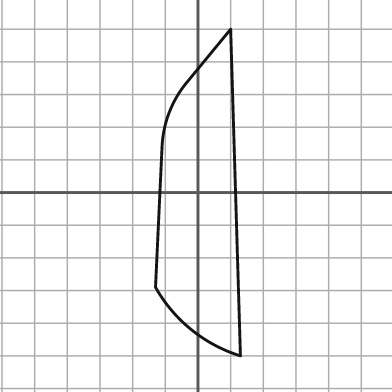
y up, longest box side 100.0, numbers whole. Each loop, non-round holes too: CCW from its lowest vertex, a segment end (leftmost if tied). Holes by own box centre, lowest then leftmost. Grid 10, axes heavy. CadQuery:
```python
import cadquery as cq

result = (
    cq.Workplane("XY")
    .moveTo(13.0, -50.0)
    .lineTo(10.0, 50.0)
    .lineTo(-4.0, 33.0)
    .threePointArc((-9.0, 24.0), (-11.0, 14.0))
    .lineTo(-13.0, -29.0)
    .threePointArc((-2.0, -42.0), (13.0, -50.0))
    .close()
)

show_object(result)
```